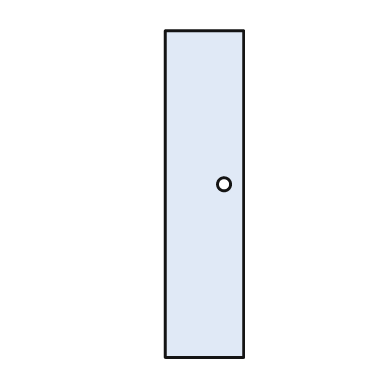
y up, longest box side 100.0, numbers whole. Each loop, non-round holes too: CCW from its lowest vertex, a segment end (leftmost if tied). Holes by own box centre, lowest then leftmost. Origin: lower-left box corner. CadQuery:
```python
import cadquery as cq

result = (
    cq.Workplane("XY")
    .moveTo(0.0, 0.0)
    .lineTo(24.0, 0.0)
    .lineTo(24.0, 100.0)
    .lineTo(0.0, 100.0)
    .close()
    .moveTo(18.0, 53.0)
    .circle(2.0)
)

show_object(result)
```